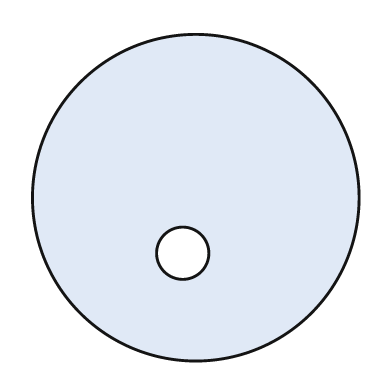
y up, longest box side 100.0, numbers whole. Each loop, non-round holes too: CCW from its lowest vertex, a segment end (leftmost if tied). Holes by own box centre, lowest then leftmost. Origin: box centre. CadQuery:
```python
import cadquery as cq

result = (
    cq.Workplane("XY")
    .moveTo(0.0, 0.0)
    .circle(50.0)
    .moveTo(-4.0, -17.0)
    .circle(8.0)
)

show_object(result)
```